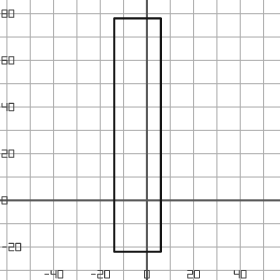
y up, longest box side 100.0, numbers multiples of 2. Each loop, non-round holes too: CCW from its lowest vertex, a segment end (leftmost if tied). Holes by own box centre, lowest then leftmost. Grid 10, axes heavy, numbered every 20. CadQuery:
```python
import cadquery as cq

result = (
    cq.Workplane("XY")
    .moveTo(-14.0, -22.0)
    .lineTo(6.0, -22.0)
    .lineTo(6.0, 78.0)
    .lineTo(-14.0, 78.0)
    .close()
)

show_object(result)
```